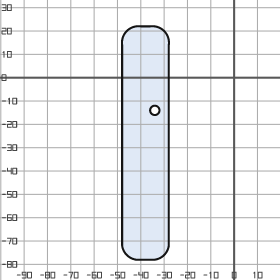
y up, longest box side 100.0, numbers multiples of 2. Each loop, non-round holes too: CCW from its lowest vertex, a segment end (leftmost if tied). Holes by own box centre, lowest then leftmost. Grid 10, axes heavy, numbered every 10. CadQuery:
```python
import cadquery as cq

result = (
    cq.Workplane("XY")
    .moveTo(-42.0, -78.0)
    .lineTo(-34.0, -78.0)
    .threePointArc((-30.0, -76.0), (-28.0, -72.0))
    .lineTo(-28.0, 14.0)
    .threePointArc((-30.0, 20.0), (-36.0, 22.0))
    .lineTo(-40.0, 22.0)
    .threePointArc((-46.0, 20.0), (-48.0, 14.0))
    .lineTo(-48.0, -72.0)
    .threePointArc((-46.0, -76.0), (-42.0, -78.0))
    .close()
    .moveTo(-34.0, -14.0)
    .circle(2.0)
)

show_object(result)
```